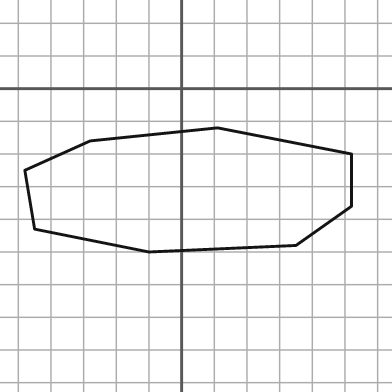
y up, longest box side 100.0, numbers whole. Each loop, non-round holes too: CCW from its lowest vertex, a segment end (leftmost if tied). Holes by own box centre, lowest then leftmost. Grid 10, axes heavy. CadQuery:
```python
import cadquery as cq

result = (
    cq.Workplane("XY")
    .moveTo(-10.0, -50.0)
    .lineTo(35.0, -48.0)
    .lineTo(52.0, -36.0)
    .lineTo(52.0, -20.0)
    .lineTo(11.0, -12.0)
    .lineTo(-28.0, -16.0)
    .lineTo(-48.0, -25.0)
    .lineTo(-45.0, -43.0)
    .close()
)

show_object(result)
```